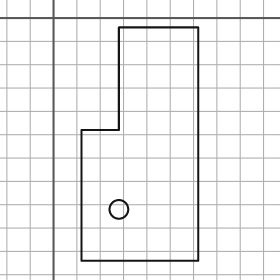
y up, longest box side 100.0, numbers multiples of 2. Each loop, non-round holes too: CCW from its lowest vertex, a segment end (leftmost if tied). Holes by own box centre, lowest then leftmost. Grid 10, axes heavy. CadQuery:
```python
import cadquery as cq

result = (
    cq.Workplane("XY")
    .moveTo(12.0, -104.0)
    .lineTo(62.0, -104.0)
    .lineTo(62.0, -4.0)
    .lineTo(28.0, -4.0)
    .lineTo(28.0, -48.0)
    .lineTo(12.0, -48.0)
    .close()
    .moveTo(28.0, -82.0)
    .circle(4.0)
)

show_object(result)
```